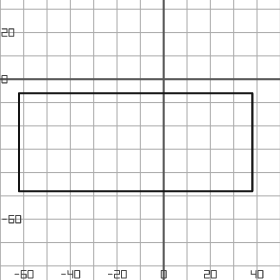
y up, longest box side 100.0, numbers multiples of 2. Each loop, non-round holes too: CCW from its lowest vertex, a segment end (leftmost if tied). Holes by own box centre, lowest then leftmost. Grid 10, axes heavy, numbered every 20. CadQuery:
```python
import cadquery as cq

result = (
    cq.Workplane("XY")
    .moveTo(-62.0, -48.0)
    .lineTo(38.0, -48.0)
    .lineTo(38.0, -6.0)
    .lineTo(-62.0, -6.0)
    .close()
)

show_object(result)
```